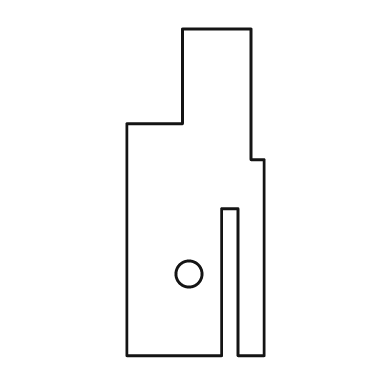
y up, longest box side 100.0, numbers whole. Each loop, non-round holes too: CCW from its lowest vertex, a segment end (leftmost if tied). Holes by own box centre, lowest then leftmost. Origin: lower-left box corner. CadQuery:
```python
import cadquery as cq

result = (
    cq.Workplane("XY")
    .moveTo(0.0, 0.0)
    .lineTo(29.0, 0.0)
    .lineTo(29.0, 45.0)
    .lineTo(34.0, 45.0)
    .lineTo(34.0, 0.0)
    .lineTo(42.0, 0.0)
    .lineTo(42.0, 60.0)
    .lineTo(38.0, 60.0)
    .lineTo(38.0, 100.0)
    .lineTo(17.0, 100.0)
    .lineTo(17.0, 71.0)
    .lineTo(0.0, 71.0)
    .close()
    .moveTo(19.0, 25.0)
    .circle(4.0)
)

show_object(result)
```